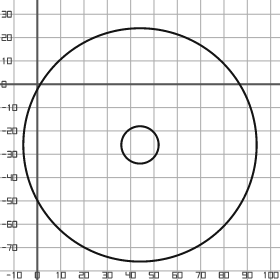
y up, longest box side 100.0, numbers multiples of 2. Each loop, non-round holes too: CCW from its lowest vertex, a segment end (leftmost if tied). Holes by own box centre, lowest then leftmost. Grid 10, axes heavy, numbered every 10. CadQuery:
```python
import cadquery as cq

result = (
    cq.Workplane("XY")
    .moveTo(44.0, -26.0)
    .circle(50.0)
    .moveTo(44.0, -26.0)
    .circle(8.0)
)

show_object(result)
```